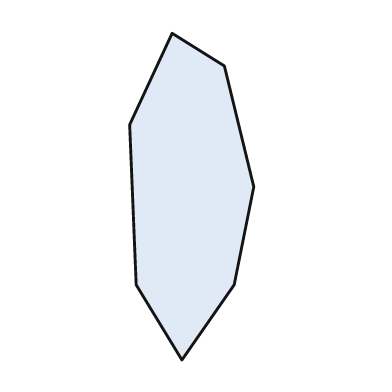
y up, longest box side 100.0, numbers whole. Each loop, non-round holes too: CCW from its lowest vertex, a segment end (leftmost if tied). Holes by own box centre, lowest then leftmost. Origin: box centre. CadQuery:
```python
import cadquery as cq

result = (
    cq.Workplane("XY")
    .moveTo(-3.0, -50.0)
    .lineTo(13.0, -27.0)
    .lineTo(19.0, 3.0)
    .lineTo(10.0, 40.0)
    .lineTo(-6.0, 50.0)
    .lineTo(-19.0, 22.0)
    .lineTo(-17.0, -27.0)
    .close()
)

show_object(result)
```